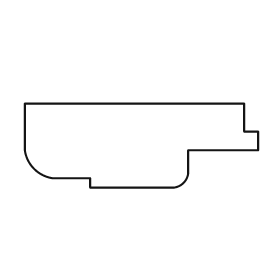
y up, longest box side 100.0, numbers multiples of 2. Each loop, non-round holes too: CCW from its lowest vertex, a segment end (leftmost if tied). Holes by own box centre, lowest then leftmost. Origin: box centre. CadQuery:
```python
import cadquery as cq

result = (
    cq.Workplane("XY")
    .moveTo(-22.0, -18.0)
    .lineTo(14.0, -18.0)
    .threePointArc((18.0, -16.0), (20.0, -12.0))
    .lineTo(20.0, -2.0)
    .lineTo(50.0, -2.0)
    .lineTo(50.0, 6.0)
    .lineTo(44.0, 6.0)
    .lineTo(44.0, 18.0)
    .lineTo(-50.0, 18.0)
    .lineTo(-50.0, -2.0)
    .threePointArc((-46.0, -10.0), (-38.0, -14.0))
    .lineTo(-22.0, -14.0)
    .close()
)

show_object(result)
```